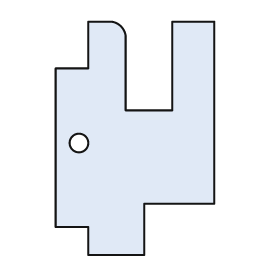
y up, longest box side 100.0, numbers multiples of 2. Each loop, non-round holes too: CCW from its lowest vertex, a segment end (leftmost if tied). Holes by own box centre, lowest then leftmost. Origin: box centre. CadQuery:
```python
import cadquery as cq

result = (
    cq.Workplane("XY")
    .moveTo(-20.0, -50.0)
    .lineTo(4.0, -50.0)
    .lineTo(4.0, -28.0)
    .lineTo(34.0, -28.0)
    .lineTo(34.0, 50.0)
    .lineTo(16.0, 50.0)
    .lineTo(16.0, 12.0)
    .lineTo(-4.0, 12.0)
    .lineTo(-4.0, 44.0)
    .threePointArc((-6.0, 48.0), (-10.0, 50.0))
    .lineTo(-20.0, 50.0)
    .lineTo(-20.0, 30.0)
    .lineTo(-34.0, 30.0)
    .lineTo(-34.0, -38.0)
    .lineTo(-20.0, -38.0)
    .close()
    .moveTo(-24.0, -2.0)
    .circle(4.0)
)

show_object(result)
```